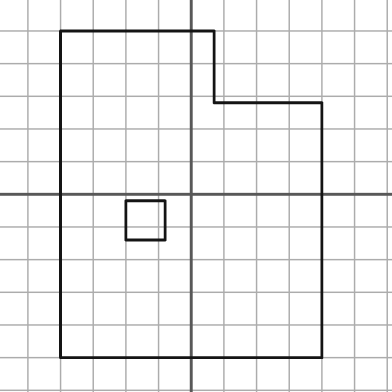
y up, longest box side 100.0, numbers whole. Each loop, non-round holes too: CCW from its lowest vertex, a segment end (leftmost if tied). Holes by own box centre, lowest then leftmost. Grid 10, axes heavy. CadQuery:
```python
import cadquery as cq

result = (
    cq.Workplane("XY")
    .moveTo(-40.0, -50.0)
    .lineTo(40.0, -50.0)
    .lineTo(40.0, 28.0)
    .lineTo(7.0, 28.0)
    .lineTo(7.0, 50.0)
    .lineTo(-40.0, 50.0)
    .close()
    .moveTo(-20.0, -14.0)
    .lineTo(-8.0, -14.0)
    .lineTo(-8.0, -2.0)
    .lineTo(-20.0, -2.0)
    .close()
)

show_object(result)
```